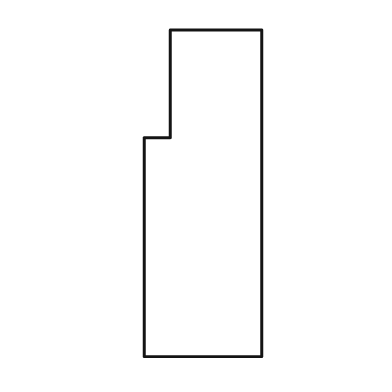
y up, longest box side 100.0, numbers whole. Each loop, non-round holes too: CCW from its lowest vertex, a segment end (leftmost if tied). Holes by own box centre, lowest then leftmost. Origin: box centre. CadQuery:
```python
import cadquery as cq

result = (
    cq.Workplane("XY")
    .moveTo(-18.0, -50.0)
    .lineTo(18.0, -50.0)
    .lineTo(18.0, 50.0)
    .lineTo(-10.0, 50.0)
    .lineTo(-10.0, 17.0)
    .lineTo(-18.0, 17.0)
    .close()
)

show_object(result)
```